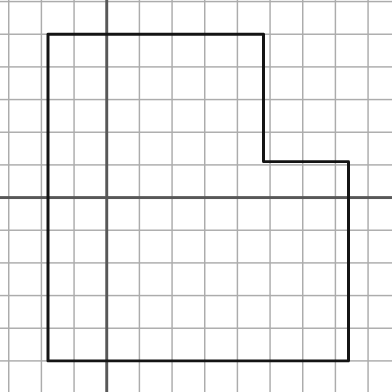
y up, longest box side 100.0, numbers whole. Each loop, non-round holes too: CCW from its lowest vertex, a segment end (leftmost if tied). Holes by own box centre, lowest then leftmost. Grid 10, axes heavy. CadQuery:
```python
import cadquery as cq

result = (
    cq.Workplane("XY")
    .moveTo(-18.0, -50.0)
    .lineTo(74.0, -50.0)
    .lineTo(74.0, 11.0)
    .lineTo(48.0, 11.0)
    .lineTo(48.0, 50.0)
    .lineTo(-18.0, 50.0)
    .close()
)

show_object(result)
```